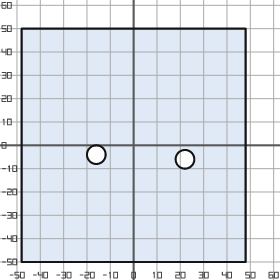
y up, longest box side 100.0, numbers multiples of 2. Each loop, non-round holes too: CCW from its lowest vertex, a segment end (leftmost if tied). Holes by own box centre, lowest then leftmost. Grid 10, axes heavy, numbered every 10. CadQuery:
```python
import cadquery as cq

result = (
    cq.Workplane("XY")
    .moveTo(-48.0, -50.0)
    .lineTo(48.0, -50.0)
    .lineTo(48.0, 50.0)
    .lineTo(-48.0, 50.0)
    .close()
    .moveTo(22.0, -6.0)
    .circle(4.0)
    .moveTo(-16.0, -4.0)
    .circle(4.0)
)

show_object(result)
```